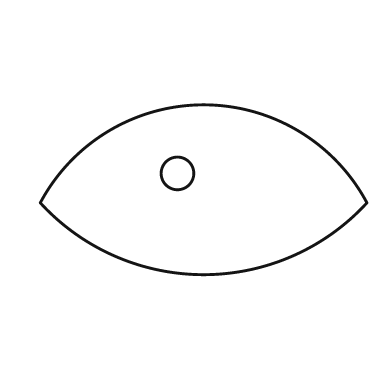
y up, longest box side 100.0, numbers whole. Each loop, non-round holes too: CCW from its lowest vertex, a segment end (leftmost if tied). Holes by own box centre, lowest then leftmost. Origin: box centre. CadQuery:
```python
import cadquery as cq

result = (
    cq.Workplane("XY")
    .moveTo(-50.0, -4.0)
    .threePointArc((0.0, -26.0), (50.0, -4.0))
    .threePointArc((0.0, 26.0), (-50.0, -4.0))
    .close()
    .moveTo(-8.0, 5.0)
    .circle(5.0)
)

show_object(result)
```